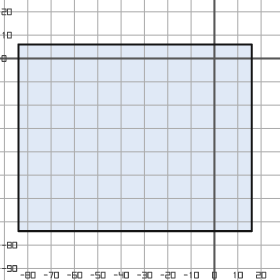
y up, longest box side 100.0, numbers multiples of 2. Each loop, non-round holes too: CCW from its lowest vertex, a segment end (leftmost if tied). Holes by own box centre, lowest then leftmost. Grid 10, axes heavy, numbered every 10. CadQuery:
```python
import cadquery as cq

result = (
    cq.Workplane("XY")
    .moveTo(-84.0, -74.0)
    .lineTo(16.0, -74.0)
    .lineTo(16.0, 6.0)
    .lineTo(-84.0, 6.0)
    .close()
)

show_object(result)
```